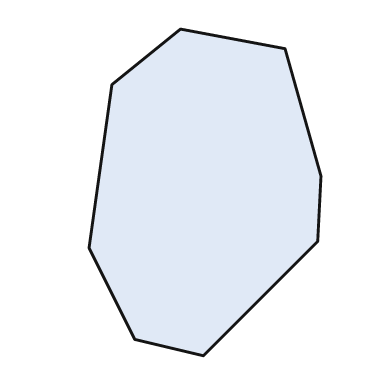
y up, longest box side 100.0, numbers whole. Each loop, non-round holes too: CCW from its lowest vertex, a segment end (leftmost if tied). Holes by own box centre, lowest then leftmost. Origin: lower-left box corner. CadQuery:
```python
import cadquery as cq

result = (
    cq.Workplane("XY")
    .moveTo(35.0, 0.0)
    .lineTo(70.0, 35.0)
    .lineTo(71.0, 55.0)
    .lineTo(60.0, 94.0)
    .lineTo(28.0, 100.0)
    .lineTo(7.0, 83.0)
    .lineTo(0.0, 33.0)
    .lineTo(14.0, 5.0)
    .close()
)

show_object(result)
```